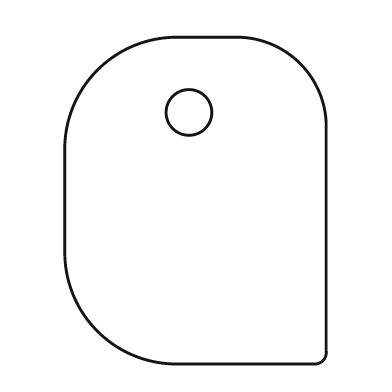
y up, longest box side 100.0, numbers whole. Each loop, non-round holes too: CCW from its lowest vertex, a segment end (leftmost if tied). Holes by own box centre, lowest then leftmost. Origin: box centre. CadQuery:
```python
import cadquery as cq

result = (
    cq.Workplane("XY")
    .moveTo(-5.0, -50.0)
    .lineTo(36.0, -50.0)
    .threePointArc((39.0, -49.0), (40.0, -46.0))
    .lineTo(40.0, 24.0)
    .threePointArc((32.0, 42.0), (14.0, 50.0))
    .lineTo(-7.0, 50.0)
    .threePointArc((-30.0, 40.0), (-40.0, 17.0))
    .lineTo(-40.0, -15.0)
    .threePointArc((-30.0, -40.0), (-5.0, -50.0))
    .close()
    .moveTo(-2.0, 27.0)
    .circle(7.0)
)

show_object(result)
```